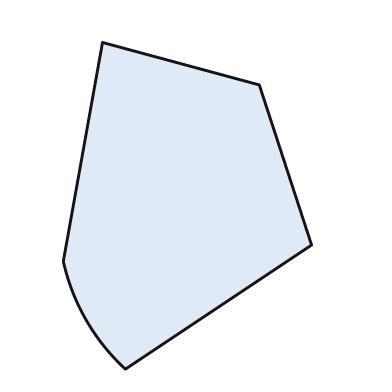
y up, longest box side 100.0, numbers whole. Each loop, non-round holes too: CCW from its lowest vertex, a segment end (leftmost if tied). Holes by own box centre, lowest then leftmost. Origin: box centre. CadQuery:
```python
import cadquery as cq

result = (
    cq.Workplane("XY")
    .moveTo(-19.0, -50.0)
    .lineTo(38.0, -12.0)
    .lineTo(22.0, 37.0)
    .lineTo(-26.0, 50.0)
    .lineTo(-38.0, -17.0)
    .threePointArc((-31.0, -35.0), (-19.0, -50.0))
    .close()
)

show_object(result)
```